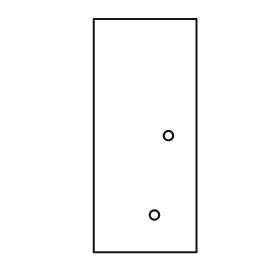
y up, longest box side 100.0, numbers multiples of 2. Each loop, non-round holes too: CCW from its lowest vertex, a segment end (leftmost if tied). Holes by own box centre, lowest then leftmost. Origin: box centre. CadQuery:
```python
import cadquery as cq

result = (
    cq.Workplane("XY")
    .moveTo(-22.0, -50.0)
    .lineTo(22.0, -50.0)
    .lineTo(22.0, 50.0)
    .lineTo(-22.0, 50.0)
    .close()
    .moveTo(4.0, -34.0)
    .circle(2.0)
    .moveTo(10.0, 0.0)
    .circle(2.0)
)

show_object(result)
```